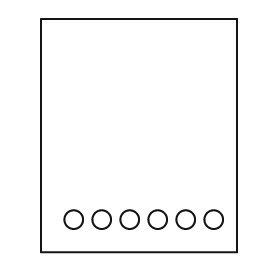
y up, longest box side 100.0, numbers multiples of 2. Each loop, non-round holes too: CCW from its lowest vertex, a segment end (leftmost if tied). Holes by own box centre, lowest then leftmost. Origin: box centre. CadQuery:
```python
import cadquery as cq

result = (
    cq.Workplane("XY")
    .moveTo(-42.0, -50.0)
    .lineTo(42.0, -50.0)
    .lineTo(42.0, 50.0)
    .lineTo(-42.0, 50.0)
    .close()
    .moveTo(-28.0, -36.0)
    .circle(4.0)
    .moveTo(-16.0, -36.0)
    .circle(4.0)
    .moveTo(-4.0, -36.0)
    .circle(4.0)
    .moveTo(8.0, -36.0)
    .circle(4.0)
    .moveTo(20.0, -36.0)
    .circle(4.0)
    .moveTo(32.0, -36.0)
    .circle(4.0)
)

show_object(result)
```